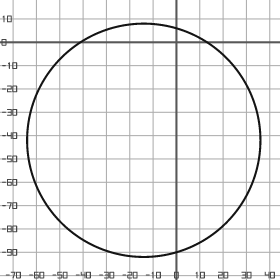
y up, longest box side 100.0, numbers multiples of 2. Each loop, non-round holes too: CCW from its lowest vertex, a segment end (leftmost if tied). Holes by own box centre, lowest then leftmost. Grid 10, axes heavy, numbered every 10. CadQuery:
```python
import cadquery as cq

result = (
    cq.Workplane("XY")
    .moveTo(-14.0, -42.0)
    .circle(50.0)
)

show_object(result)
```